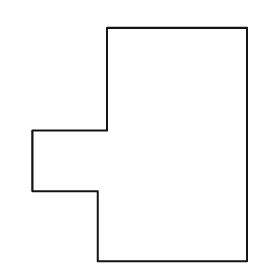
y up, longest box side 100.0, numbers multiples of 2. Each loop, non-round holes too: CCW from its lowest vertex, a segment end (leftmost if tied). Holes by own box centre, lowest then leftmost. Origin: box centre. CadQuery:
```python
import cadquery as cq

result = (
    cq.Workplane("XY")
    .moveTo(-18.0, -50.0)
    .lineTo(46.0, -50.0)
    .lineTo(46.0, 50.0)
    .lineTo(-14.0, 50.0)
    .lineTo(-14.0, 6.0)
    .lineTo(-46.0, 6.0)
    .lineTo(-46.0, -20.0)
    .lineTo(-18.0, -20.0)
    .close()
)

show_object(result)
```